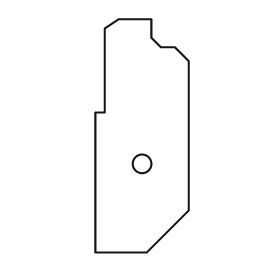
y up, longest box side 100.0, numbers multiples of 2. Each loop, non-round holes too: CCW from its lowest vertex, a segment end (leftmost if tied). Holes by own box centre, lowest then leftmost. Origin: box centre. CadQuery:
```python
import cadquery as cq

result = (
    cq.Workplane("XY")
    .moveTo(-20.0, -50.0)
    .lineTo(2.0, -50.0)
    .lineTo(20.0, -32.0)
    .lineTo(20.0, 32.0)
    .lineTo(14.0, 38.0)
    .lineTo(8.0, 38.0)
    .lineTo(4.0, 42.0)
    .lineTo(4.0, 50.0)
    .lineTo(-10.0, 50.0)
    .lineTo(-16.0, 46.0)
    .lineTo(-16.0, 10.0)
    .lineTo(-20.0, 10.0)
    .close()
    .moveTo(0.0, -12.0)
    .circle(4.0)
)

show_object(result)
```